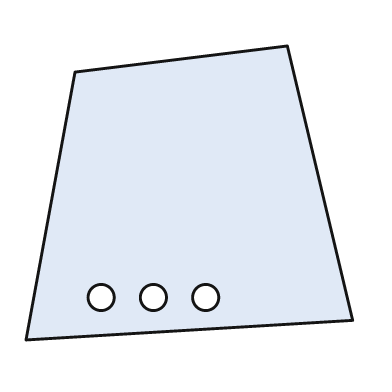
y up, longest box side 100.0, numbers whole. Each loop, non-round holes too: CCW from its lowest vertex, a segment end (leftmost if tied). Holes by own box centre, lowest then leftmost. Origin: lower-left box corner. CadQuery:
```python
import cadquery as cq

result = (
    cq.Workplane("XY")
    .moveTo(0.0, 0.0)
    .lineTo(100.0, 6.0)
    .lineTo(80.0, 90.0)
    .lineTo(15.0, 82.0)
    .close()
    .moveTo(23.0, 13.0)
    .circle(4.0)
    .moveTo(39.0, 13.0)
    .circle(4.0)
    .moveTo(55.0, 13.0)
    .circle(4.0)
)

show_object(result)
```